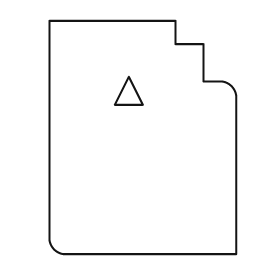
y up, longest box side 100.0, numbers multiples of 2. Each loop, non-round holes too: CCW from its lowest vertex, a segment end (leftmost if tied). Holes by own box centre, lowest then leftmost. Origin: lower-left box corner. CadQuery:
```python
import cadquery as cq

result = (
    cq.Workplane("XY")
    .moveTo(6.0, 0.0)
    .lineTo(80.0, 0.0)
    .lineTo(80.0, 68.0)
    .threePointArc((78.0, 72.0), (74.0, 74.0))
    .lineTo(66.0, 74.0)
    .lineTo(66.0, 90.0)
    .lineTo(54.0, 90.0)
    .lineTo(54.0, 100.0)
    .lineTo(0.0, 100.0)
    .lineTo(0.0, 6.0)
    .threePointArc((2.0, 2.0), (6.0, 0.0))
    .close()
    .moveTo(28.0, 64.0)
    .lineTo(40.0, 64.0)
    .lineTo(34.0, 76.0)
    .close()
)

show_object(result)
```